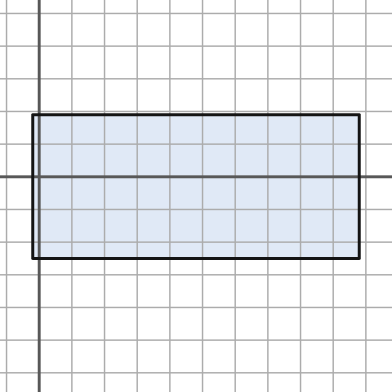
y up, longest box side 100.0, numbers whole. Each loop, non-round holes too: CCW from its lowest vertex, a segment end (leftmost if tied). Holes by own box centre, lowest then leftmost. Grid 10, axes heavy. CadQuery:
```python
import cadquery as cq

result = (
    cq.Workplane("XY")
    .moveTo(-2.0, -25.0)
    .lineTo(98.0, -25.0)
    .lineTo(98.0, 19.0)
    .lineTo(-2.0, 19.0)
    .close()
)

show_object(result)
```